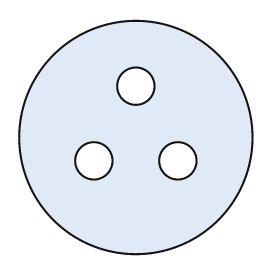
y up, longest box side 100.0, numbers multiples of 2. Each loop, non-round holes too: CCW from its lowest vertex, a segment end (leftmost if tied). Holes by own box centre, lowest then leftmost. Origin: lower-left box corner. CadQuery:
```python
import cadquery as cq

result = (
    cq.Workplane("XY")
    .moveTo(50.0, 50.0)
    .circle(50.0)
    .moveTo(32.0, 40.0)
    .circle(8.0)
    .moveTo(68.0, 40.0)
    .circle(8.0)
    .moveTo(50.0, 72.0)
    .circle(8.0)
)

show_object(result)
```